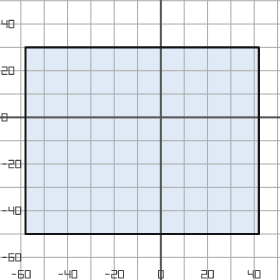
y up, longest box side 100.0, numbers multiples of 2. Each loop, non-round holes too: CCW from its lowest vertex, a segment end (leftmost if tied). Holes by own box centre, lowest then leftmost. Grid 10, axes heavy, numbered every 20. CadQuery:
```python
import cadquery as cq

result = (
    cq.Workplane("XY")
    .moveTo(-58.0, -50.0)
    .lineTo(42.0, -50.0)
    .lineTo(42.0, 30.0)
    .lineTo(-58.0, 30.0)
    .close()
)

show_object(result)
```